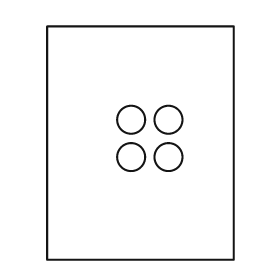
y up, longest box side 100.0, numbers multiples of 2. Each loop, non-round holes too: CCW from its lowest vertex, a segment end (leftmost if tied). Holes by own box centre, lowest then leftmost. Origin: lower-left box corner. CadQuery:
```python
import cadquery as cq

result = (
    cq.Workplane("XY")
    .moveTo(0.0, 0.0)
    .lineTo(80.0, 0.0)
    .lineTo(80.0, 100.0)
    .lineTo(0.0, 100.0)
    .close()
    .moveTo(36.0, 44.0)
    .circle(6.0)
    .moveTo(52.0, 44.0)
    .circle(6.0)
    .moveTo(36.0, 60.0)
    .circle(6.0)
    .moveTo(52.0, 60.0)
    .circle(6.0)
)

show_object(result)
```